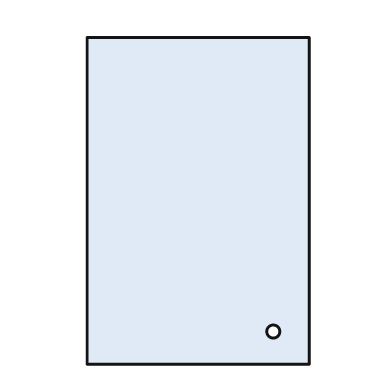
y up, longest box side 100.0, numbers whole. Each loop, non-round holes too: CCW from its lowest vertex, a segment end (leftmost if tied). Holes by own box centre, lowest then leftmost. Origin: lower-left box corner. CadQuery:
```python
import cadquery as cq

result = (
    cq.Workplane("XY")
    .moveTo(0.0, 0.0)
    .lineTo(68.0, 0.0)
    .lineTo(68.0, 100.0)
    .lineTo(0.0, 100.0)
    .close()
    .moveTo(57.0, 10.0)
    .circle(2.0)
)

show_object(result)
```